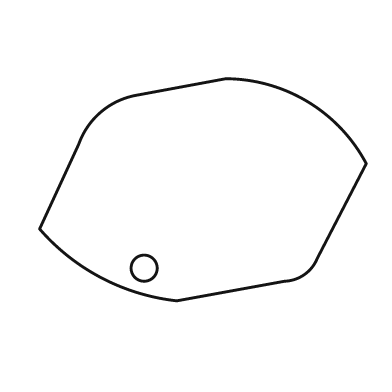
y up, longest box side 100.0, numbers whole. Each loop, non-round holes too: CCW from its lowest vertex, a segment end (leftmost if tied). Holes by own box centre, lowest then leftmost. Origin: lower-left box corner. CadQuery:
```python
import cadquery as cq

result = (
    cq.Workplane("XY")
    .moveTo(42.0, 0.0)
    .lineTo(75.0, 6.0)
    .threePointArc((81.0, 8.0), (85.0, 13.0))
    .lineTo(100.0, 42.0)
    .threePointArc((82.0, 61.0), (57.0, 68.0))
    .lineTo(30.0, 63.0)
    .threePointArc((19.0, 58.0), (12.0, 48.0))
    .lineTo(0.0, 22.0)
    .threePointArc((19.0, 7.0), (42.0, 0.0))
    .close()
    .moveTo(32.0, 10.0)
    .circle(4.0)
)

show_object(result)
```